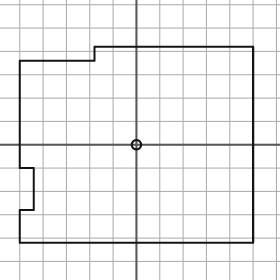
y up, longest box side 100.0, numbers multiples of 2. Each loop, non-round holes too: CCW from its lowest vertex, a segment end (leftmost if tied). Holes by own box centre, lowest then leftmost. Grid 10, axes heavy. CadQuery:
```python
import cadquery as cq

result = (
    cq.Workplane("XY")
    .moveTo(-50.0, -42.0)
    .lineTo(50.0, -42.0)
    .lineTo(50.0, 42.0)
    .lineTo(-18.0, 42.0)
    .lineTo(-18.0, 36.0)
    .lineTo(-50.0, 36.0)
    .lineTo(-50.0, -10.0)
    .lineTo(-44.0, -10.0)
    .lineTo(-44.0, -28.0)
    .lineTo(-50.0, -28.0)
    .close()
    .moveTo(0.0, 0.0)
    .circle(2.0)
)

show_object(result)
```